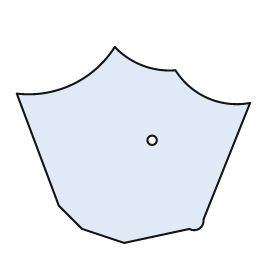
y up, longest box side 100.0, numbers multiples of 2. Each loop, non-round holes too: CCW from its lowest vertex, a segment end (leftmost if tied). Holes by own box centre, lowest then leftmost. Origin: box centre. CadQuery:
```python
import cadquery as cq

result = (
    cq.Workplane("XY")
    .moveTo(-4.0, -42.0)
    .lineTo(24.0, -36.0)
    .threePointArc((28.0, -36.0), (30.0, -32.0))
    .lineTo(50.0, 18.0)
    .threePointArc((32.0, 20.0), (18.0, 32.0))
    .threePointArc((4.0, 34.0), (-8.0, 42.0))
    .threePointArc((-26.0, 26.0), (-50.0, 22.0))
    .lineTo(-32.0, -26.0)
    .lineTo(-22.0, -36.0)
    .close()
    .moveTo(8.0, 2.0)
    .circle(2.0)
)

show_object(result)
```